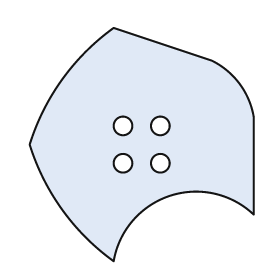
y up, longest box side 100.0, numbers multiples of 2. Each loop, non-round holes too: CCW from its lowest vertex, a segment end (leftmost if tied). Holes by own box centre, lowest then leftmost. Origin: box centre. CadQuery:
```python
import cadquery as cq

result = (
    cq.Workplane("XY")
    .moveTo(-12.0, -50.0)
    .threePointArc((12.0, -22.0), (48.0, -30.0))
    .lineTo(48.0, 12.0)
    .threePointArc((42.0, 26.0), (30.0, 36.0))
    .lineTo(-12.0, 50.0)
    .threePointArc((-34.0, 28.0), (-48.0, 0.0))
    .threePointArc((-34.0, -28.0), (-12.0, -50.0))
    .close()
    .moveTo(-8.0, -8.0)
    .circle(4.0)
    .moveTo(8.0, -8.0)
    .circle(4.0)
    .moveTo(-8.0, 8.0)
    .circle(4.0)
    .moveTo(8.0, 8.0)
    .circle(4.0)
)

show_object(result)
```